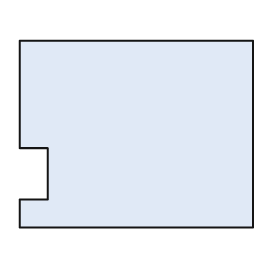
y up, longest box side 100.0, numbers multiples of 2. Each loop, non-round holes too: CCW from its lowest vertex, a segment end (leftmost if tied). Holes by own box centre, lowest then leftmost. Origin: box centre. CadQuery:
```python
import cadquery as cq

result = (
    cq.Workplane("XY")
    .moveTo(-50.0, -40.0)
    .lineTo(50.0, -40.0)
    .lineTo(50.0, 40.0)
    .lineTo(-50.0, 40.0)
    .lineTo(-50.0, -6.0)
    .lineTo(-38.0, -6.0)
    .lineTo(-38.0, -28.0)
    .lineTo(-50.0, -28.0)
    .close()
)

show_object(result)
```